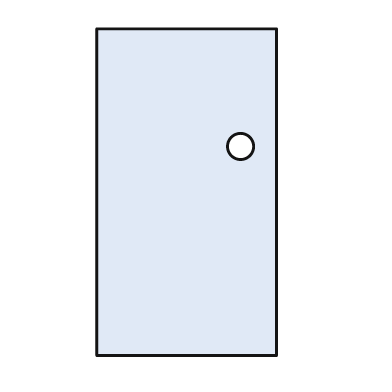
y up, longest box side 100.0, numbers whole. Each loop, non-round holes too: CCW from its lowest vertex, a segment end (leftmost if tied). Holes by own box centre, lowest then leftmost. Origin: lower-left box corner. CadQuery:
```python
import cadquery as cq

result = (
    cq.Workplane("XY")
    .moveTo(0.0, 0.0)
    .lineTo(55.0, 0.0)
    .lineTo(55.0, 100.0)
    .lineTo(0.0, 100.0)
    .close()
    .moveTo(44.0, 64.0)
    .circle(4.0)
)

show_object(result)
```